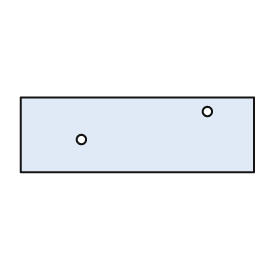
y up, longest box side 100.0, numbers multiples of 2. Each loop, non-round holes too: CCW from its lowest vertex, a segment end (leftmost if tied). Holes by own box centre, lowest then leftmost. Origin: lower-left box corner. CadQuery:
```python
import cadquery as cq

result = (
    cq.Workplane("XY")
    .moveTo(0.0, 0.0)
    .lineTo(100.0, 0.0)
    .lineTo(100.0, 32.0)
    .lineTo(0.0, 32.0)
    .close()
    .moveTo(26.0, 14.0)
    .circle(2.0)
    .moveTo(80.0, 26.0)
    .circle(2.0)
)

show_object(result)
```